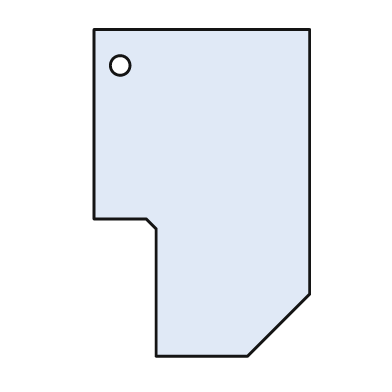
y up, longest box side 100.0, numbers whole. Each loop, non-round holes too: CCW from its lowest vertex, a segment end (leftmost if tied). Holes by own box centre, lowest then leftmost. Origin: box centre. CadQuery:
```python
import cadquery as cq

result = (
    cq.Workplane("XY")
    .moveTo(-14.0, -50.0)
    .lineTo(14.0, -50.0)
    .lineTo(33.0, -31.0)
    .lineTo(33.0, 50.0)
    .lineTo(-33.0, 50.0)
    .lineTo(-33.0, -8.0)
    .lineTo(-17.0, -8.0)
    .lineTo(-14.0, -11.0)
    .close()
    .moveTo(-25.0, 39.0)
    .circle(3.0)
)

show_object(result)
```